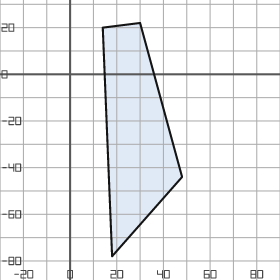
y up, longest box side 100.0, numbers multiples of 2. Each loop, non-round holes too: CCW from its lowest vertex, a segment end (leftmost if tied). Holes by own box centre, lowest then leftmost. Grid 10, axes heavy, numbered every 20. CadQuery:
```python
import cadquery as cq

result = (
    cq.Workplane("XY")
    .moveTo(18.0, -78.0)
    .lineTo(48.0, -44.0)
    .lineTo(30.0, 22.0)
    .lineTo(14.0, 20.0)
    .close()
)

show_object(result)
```